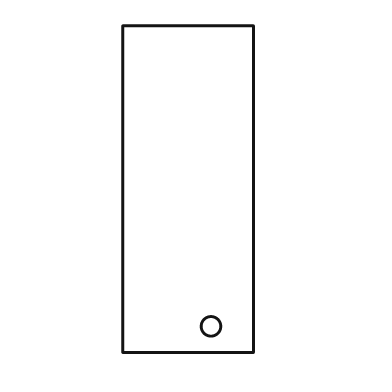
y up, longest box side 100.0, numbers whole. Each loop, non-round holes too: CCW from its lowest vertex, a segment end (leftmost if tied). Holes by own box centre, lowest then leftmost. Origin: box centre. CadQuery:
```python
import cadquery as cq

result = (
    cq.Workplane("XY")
    .moveTo(-20.0, -50.0)
    .lineTo(20.0, -50.0)
    .lineTo(20.0, 50.0)
    .lineTo(-20.0, 50.0)
    .close()
    .moveTo(7.0, -42.0)
    .circle(3.0)
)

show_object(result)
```